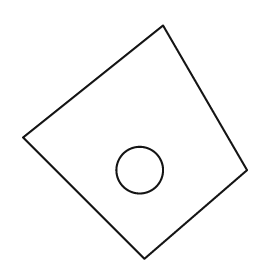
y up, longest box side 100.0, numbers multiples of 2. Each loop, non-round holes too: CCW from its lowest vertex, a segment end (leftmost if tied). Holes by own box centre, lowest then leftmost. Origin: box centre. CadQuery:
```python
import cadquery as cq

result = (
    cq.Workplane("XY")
    .moveTo(4.0, -50.0)
    .lineTo(48.0, -12.0)
    .lineTo(12.0, 50.0)
    .lineTo(-48.0, 2.0)
    .close()
    .moveTo(2.0, -12.0)
    .circle(10.0)
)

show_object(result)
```